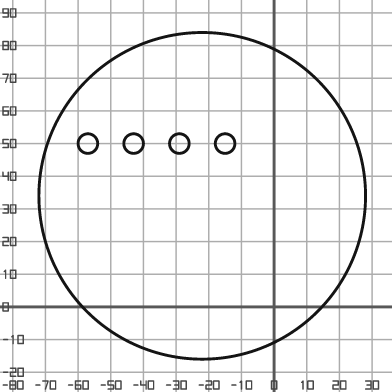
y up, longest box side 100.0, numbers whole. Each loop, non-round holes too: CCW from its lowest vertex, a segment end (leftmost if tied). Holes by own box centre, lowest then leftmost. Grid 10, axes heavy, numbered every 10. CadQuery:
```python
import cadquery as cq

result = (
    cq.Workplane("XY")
    .moveTo(-22.0, 34.0)
    .circle(50.0)
    .moveTo(-57.0, 50.0)
    .circle(3.0)
    .moveTo(-43.0, 50.0)
    .circle(3.0)
    .moveTo(-29.0, 50.0)
    .circle(3.0)
    .moveTo(-15.0, 50.0)
    .circle(3.0)
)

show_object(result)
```